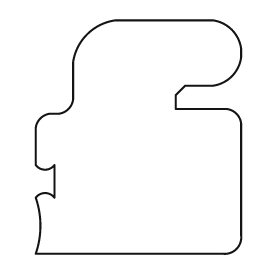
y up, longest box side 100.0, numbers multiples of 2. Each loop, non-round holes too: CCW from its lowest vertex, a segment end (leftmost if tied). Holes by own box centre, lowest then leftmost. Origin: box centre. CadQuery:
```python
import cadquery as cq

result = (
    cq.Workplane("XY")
    .moveTo(-44.0, -50.0)
    .lineTo(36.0, -50.0)
    .threePointArc((42.0, -48.0), (44.0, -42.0))
    .lineTo(44.0, 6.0)
    .threePointArc((42.0, 10.0), (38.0, 12.0))
    .lineTo(16.0, 12.0)
    .lineTo(16.0, 18.0)
    .lineTo(20.0, 22.0)
    .lineTo(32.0, 22.0)
    .threePointArc((40.0, 26.0), (44.0, 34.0))
    .lineTo(44.0, 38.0)
    .threePointArc((40.0, 46.0), (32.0, 50.0))
    .lineTo(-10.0, 50.0)
    .threePointArc((-22.0, 44.0), (-28.0, 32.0))
    .lineTo(-28.0, 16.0)
    .threePointArc((-30.0, 12.0), (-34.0, 10.0))
    .lineTo(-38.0, 10.0)
    .threePointArc((-42.0, 8.0), (-44.0, 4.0))
    .lineTo(-44.0, -12.0)
    .threePointArc((-40.0, -14.0), (-36.0, -12.0))
    .lineTo(-36.0, -26.0)
    .threePointArc((-40.0, -24.0), (-44.0, -26.0))
    .threePointArc((-42.0, -38.0), (-44.0, -50.0))
    .close()
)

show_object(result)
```